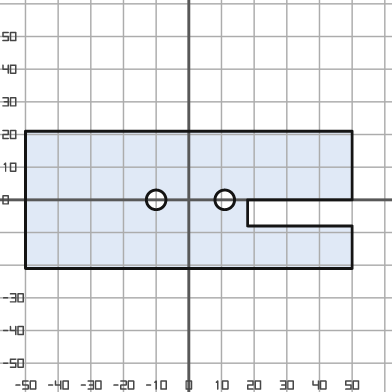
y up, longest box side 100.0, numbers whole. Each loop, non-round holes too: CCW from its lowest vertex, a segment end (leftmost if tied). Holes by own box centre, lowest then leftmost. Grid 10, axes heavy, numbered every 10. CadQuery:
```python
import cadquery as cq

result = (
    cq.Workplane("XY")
    .moveTo(-50.0, -21.0)
    .lineTo(50.0, -21.0)
    .lineTo(50.0, -8.0)
    .lineTo(18.0, -8.0)
    .lineTo(18.0, 0.0)
    .lineTo(50.0, 0.0)
    .lineTo(50.0, 21.0)
    .lineTo(-50.0, 21.0)
    .close()
    .moveTo(-10.0, 0.0)
    .circle(3.0)
    .moveTo(11.0, 0.0)
    .circle(3.0)
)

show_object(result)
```